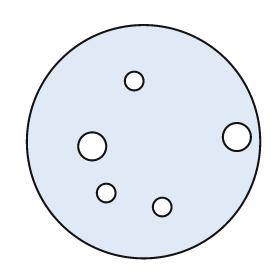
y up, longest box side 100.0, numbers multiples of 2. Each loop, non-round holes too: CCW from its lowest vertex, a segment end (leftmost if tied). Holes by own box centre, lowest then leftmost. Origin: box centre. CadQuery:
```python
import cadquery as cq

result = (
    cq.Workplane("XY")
    .moveTo(0.0, 0.0)
    .circle(50.0)
    .moveTo(8.0, -28.0)
    .circle(4.0)
    .moveTo(-16.0, -22.0)
    .circle(4.0)
    .moveTo(-22.0, -2.0)
    .circle(6.0)
    .moveTo(40.0, 2.0)
    .circle(6.0)
    .moveTo(-4.0, 26.0)
    .circle(4.0)
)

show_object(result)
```